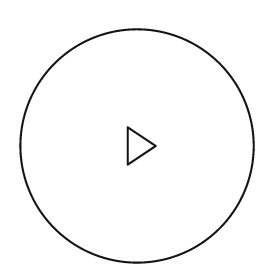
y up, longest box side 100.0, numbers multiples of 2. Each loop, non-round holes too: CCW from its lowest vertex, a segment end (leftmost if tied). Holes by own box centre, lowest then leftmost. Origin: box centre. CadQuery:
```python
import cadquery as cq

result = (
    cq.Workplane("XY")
    .moveTo(0.0, 0.0)
    .circle(50.0)
    .moveTo(-4.0, -8.0)
    .lineTo(8.0, 0.0)
    .lineTo(-4.0, 8.0)
    .close()
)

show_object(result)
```